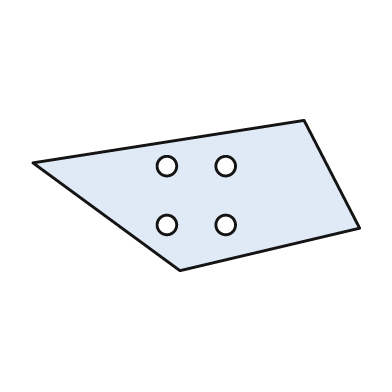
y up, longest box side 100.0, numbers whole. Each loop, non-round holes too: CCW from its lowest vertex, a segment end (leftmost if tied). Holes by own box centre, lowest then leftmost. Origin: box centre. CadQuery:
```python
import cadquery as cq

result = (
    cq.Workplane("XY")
    .moveTo(-5.0, -23.0)
    .lineTo(50.0, -10.0)
    .lineTo(33.0, 23.0)
    .lineTo(-50.0, 10.0)
    .close()
    .moveTo(-9.0, -9.0)
    .circle(3.0)
    .moveTo(9.0, -9.0)
    .circle(3.0)
    .moveTo(-9.0, 9.0)
    .circle(3.0)
    .moveTo(9.0, 9.0)
    .circle(3.0)
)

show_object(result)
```